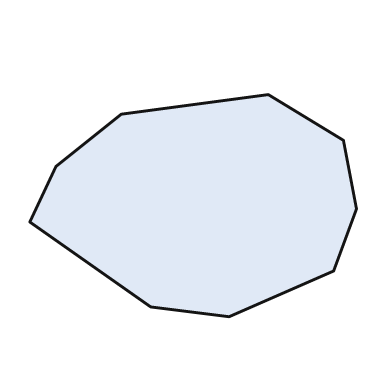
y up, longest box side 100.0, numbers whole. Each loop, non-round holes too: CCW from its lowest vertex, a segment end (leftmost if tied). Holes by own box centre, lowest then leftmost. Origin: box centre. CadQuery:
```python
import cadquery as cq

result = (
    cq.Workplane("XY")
    .moveTo(11.0, -34.0)
    .lineTo(43.0, -20.0)
    .lineTo(50.0, -1.0)
    .lineTo(46.0, 20.0)
    .lineTo(23.0, 34.0)
    .lineTo(-22.0, 28.0)
    .lineTo(-42.0, 12.0)
    .lineTo(-50.0, -5.0)
    .lineTo(-13.0, -31.0)
    .close()
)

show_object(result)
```